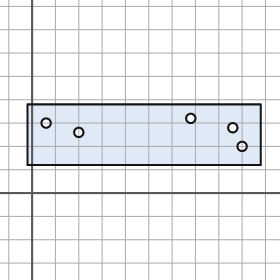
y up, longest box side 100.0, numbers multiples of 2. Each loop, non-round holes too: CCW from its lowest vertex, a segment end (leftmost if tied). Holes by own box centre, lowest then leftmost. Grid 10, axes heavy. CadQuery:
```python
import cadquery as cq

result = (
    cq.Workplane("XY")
    .moveTo(-2.0, 12.0)
    .lineTo(98.0, 12.0)
    .lineTo(98.0, 38.0)
    .lineTo(-2.0, 38.0)
    .close()
    .moveTo(90.0, 20.0)
    .circle(2.0)
    .moveTo(20.0, 26.0)
    .circle(2.0)
    .moveTo(86.0, 28.0)
    .circle(2.0)
    .moveTo(6.0, 30.0)
    .circle(2.0)
    .moveTo(68.0, 32.0)
    .circle(2.0)
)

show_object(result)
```